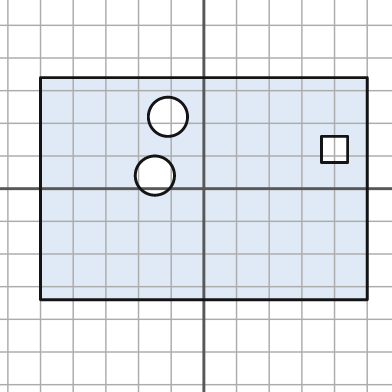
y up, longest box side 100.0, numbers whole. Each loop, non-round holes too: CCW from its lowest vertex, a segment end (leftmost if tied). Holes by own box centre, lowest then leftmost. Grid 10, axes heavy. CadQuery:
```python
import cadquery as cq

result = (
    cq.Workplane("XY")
    .moveTo(-50.0, -34.0)
    .lineTo(50.0, -34.0)
    .lineTo(50.0, 34.0)
    .lineTo(-50.0, 34.0)
    .close()
    .moveTo(-15.0, 4.0)
    .circle(6.0)
    .moveTo(36.0, 8.0)
    .lineTo(44.0, 8.0)
    .lineTo(44.0, 16.0)
    .lineTo(36.0, 16.0)
    .close()
    .moveTo(-11.0, 22.0)
    .circle(6.0)
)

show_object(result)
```